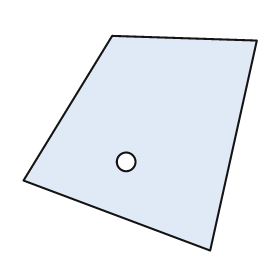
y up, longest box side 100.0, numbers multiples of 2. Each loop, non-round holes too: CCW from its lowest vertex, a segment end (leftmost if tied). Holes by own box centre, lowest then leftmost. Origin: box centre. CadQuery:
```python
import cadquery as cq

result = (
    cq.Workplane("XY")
    .moveTo(30.0, -46.0)
    .lineTo(50.0, 44.0)
    .lineTo(-12.0, 46.0)
    .lineTo(-50.0, -16.0)
    .close()
    .moveTo(-6.0, -8.0)
    .circle(4.0)
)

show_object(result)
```